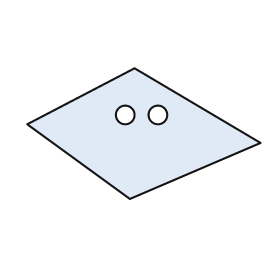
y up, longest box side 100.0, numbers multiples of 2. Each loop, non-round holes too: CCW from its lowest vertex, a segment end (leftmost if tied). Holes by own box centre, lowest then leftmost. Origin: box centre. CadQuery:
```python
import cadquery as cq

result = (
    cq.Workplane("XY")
    .moveTo(-6.0, -28.0)
    .lineTo(50.0, -4.0)
    .lineTo(-4.0, 28.0)
    .lineTo(-50.0, 4.0)
    .close()
    .moveTo(-8.0, 8.0)
    .circle(4.0)
    .moveTo(6.0, 8.0)
    .circle(4.0)
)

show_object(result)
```